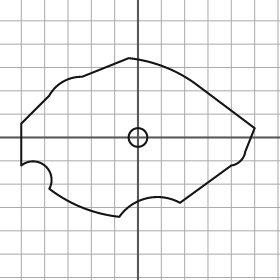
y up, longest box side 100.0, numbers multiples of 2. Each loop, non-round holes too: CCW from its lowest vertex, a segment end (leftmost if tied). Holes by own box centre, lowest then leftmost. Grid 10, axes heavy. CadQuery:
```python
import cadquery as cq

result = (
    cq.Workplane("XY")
    .moveTo(-8.0, -34.0)
    .threePointArc((4.0, -26.0), (18.0, -28.0))
    .lineTo(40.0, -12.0)
    .threePointArc((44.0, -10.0), (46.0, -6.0))
    .lineTo(50.0, 4.0)
    .lineTo(26.0, 22.0)
    .threePointArc((12.0, 30.0), (-4.0, 34.0))
    .lineTo(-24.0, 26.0)
    .threePointArc((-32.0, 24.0), (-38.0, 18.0))
    .lineTo(-50.0, 6.0)
    .lineTo(-50.0, -12.0)
    .threePointArc((-40.0, -12.0), (-38.0, -22.0))
    .threePointArc((-24.0, -30.0), (-8.0, -34.0))
    .close()
    .moveTo(0.0, 0.0)
    .circle(4.0)
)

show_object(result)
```